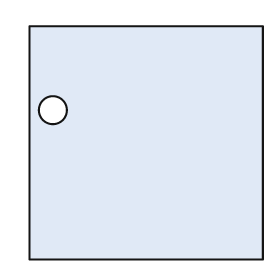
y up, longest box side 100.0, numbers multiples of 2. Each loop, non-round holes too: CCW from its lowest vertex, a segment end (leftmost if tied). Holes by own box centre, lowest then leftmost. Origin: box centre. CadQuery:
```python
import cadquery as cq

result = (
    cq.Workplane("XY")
    .moveTo(-50.0, -50.0)
    .lineTo(50.0, -50.0)
    .lineTo(50.0, 50.0)
    .lineTo(-50.0, 50.0)
    .close()
    .moveTo(-40.0, 14.0)
    .circle(6.0)
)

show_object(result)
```